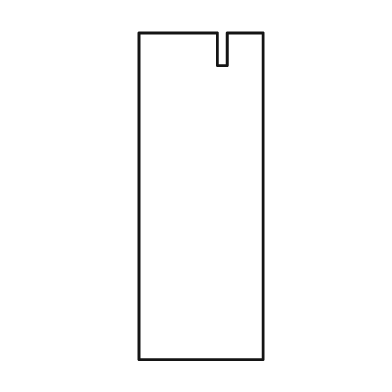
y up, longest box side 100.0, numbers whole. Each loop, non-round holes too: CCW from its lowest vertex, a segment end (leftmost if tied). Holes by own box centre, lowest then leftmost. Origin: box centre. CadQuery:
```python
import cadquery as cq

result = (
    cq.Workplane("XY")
    .moveTo(-19.0, -50.0)
    .lineTo(19.0, -50.0)
    .lineTo(19.0, 50.0)
    .lineTo(8.0, 50.0)
    .lineTo(8.0, 40.0)
    .lineTo(5.0, 40.0)
    .lineTo(5.0, 50.0)
    .lineTo(-19.0, 50.0)
    .close()
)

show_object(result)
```